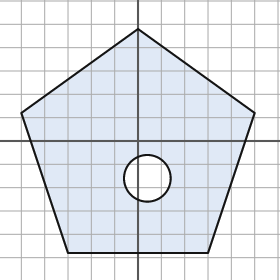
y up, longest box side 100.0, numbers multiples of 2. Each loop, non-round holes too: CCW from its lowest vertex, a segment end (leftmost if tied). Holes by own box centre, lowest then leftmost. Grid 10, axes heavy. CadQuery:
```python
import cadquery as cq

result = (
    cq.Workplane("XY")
    .moveTo(-30.0, -48.0)
    .lineTo(30.0, -48.0)
    .lineTo(50.0, 12.0)
    .lineTo(0.0, 48.0)
    .lineTo(-50.0, 12.0)
    .close()
    .moveTo(4.0, -16.0)
    .circle(10.0)
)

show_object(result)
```